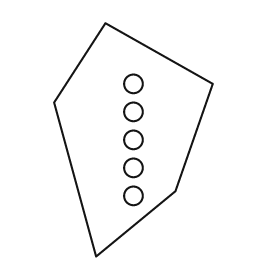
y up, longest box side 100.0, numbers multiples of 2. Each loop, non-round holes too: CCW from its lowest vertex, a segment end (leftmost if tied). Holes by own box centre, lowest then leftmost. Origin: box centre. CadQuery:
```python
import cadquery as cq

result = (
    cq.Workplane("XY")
    .moveTo(-16.0, -50.0)
    .lineTo(18.0, -22.0)
    .lineTo(34.0, 24.0)
    .lineTo(-12.0, 50.0)
    .lineTo(-34.0, 16.0)
    .close()
    .moveTo(0.0, -24.0)
    .circle(4.0)
    .moveTo(0.0, -12.0)
    .circle(4.0)
    .moveTo(0.0, 0.0)
    .circle(4.0)
    .moveTo(0.0, 12.0)
    .circle(4.0)
    .moveTo(0.0, 24.0)
    .circle(4.0)
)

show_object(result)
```